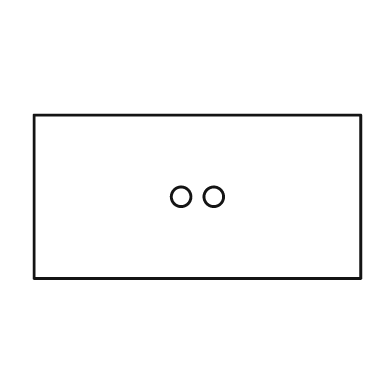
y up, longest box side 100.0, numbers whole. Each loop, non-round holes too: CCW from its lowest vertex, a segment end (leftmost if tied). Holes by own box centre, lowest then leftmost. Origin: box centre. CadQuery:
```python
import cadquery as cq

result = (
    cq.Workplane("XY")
    .moveTo(-50.0, -25.0)
    .lineTo(50.0, -25.0)
    .lineTo(50.0, 25.0)
    .lineTo(-50.0, 25.0)
    .close()
    .moveTo(-5.0, 0.0)
    .circle(3.0)
    .moveTo(5.0, 0.0)
    .circle(3.0)
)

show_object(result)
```